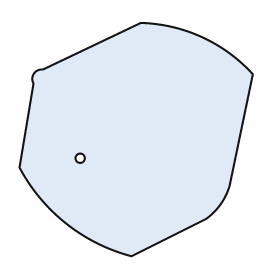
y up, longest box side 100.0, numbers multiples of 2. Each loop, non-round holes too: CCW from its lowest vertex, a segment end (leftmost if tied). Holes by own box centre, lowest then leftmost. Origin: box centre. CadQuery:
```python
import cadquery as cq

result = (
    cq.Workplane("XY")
    .moveTo(-2.0, -50.0)
    .lineTo(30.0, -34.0)
    .threePointArc((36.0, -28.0), (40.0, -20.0))
    .lineTo(50.0, 28.0)
    .threePointArc((28.0, 44.0), (2.0, 50.0))
    .lineTo(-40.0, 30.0)
    .threePointArc((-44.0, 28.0), (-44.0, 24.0))
    .lineTo(-50.0, -12.0)
    .threePointArc((-30.0, -36.0), (-2.0, -50.0))
    .close()
    .moveTo(-24.0, -8.0)
    .circle(2.0)
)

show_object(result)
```